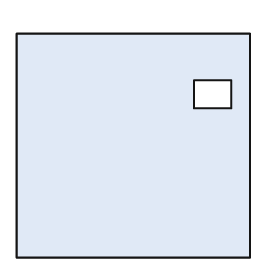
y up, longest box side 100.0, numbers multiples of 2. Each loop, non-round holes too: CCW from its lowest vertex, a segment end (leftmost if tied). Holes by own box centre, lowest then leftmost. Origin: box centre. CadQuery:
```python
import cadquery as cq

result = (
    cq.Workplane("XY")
    .moveTo(-50.0, -48.0)
    .lineTo(50.0, -48.0)
    .lineTo(50.0, 48.0)
    .lineTo(-50.0, 48.0)
    .close()
    .moveTo(26.0, 16.0)
    .lineTo(42.0, 16.0)
    .lineTo(42.0, 28.0)
    .lineTo(26.0, 28.0)
    .close()
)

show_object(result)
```